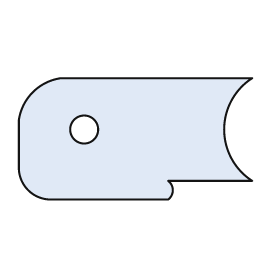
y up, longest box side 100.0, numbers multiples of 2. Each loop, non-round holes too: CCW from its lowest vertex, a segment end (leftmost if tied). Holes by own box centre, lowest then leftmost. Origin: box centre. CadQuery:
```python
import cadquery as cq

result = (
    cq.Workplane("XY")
    .moveTo(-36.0, -26.0)
    .lineTo(14.0, -26.0)
    .threePointArc((16.0, -22.0), (14.0, -18.0))
    .lineTo(50.0, -18.0)
    .threePointArc((38.0, 4.0), (50.0, 26.0))
    .lineTo(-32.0, 26.0)
    .threePointArc((-44.0, 20.0), (-50.0, 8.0))
    .lineTo(-50.0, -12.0)
    .threePointArc((-46.0, -22.0), (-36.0, -26.0))
    .close()
    .moveTo(-22.0, 4.0)
    .circle(6.0)
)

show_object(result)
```